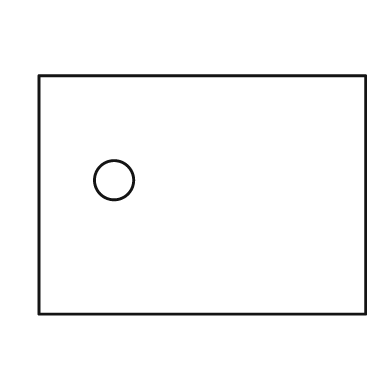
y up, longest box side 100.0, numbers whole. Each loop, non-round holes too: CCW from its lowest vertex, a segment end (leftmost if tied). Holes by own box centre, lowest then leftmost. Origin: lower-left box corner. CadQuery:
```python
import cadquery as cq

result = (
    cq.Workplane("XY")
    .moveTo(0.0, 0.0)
    .lineTo(100.0, 0.0)
    .lineTo(100.0, 73.0)
    .lineTo(0.0, 73.0)
    .close()
    .moveTo(23.0, 41.0)
    .circle(6.0)
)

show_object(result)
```